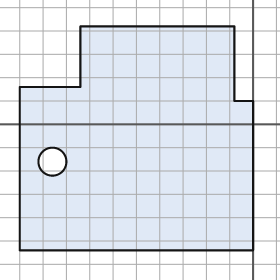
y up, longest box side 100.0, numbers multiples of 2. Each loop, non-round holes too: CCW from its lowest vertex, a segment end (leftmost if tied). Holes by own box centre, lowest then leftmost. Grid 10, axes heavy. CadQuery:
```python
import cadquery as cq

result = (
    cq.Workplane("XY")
    .moveTo(-100.0, -54.0)
    .lineTo(0.0, -54.0)
    .lineTo(0.0, 10.0)
    .lineTo(-8.0, 10.0)
    .lineTo(-8.0, 42.0)
    .lineTo(-74.0, 42.0)
    .lineTo(-74.0, 16.0)
    .lineTo(-100.0, 16.0)
    .close()
    .moveTo(-86.0, -16.0)
    .circle(6.0)
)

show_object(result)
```